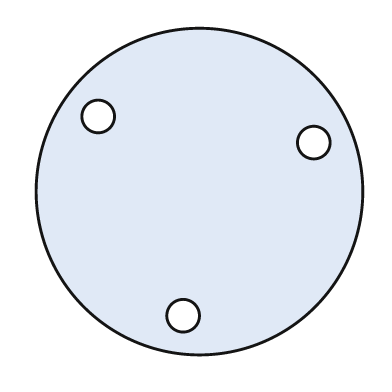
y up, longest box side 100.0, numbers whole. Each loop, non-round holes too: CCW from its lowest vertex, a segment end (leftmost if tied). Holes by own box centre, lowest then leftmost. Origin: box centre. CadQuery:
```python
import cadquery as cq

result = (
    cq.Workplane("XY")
    .moveTo(0.0, 0.0)
    .circle(50.0)
    .moveTo(-5.0, -38.0)
    .circle(5.0)
    .moveTo(35.0, 15.0)
    .circle(5.0)
    .moveTo(-31.0, 23.0)
    .circle(5.0)
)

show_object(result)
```